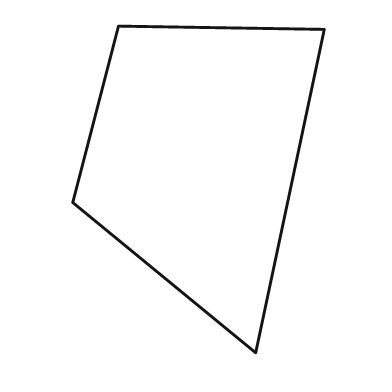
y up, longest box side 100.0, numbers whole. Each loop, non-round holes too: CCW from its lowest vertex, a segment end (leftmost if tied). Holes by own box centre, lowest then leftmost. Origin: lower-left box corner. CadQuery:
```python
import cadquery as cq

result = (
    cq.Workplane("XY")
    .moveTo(56.0, 0.0)
    .lineTo(77.0, 99.0)
    .lineTo(14.0, 100.0)
    .lineTo(0.0, 46.0)
    .close()
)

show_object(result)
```